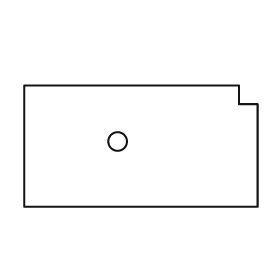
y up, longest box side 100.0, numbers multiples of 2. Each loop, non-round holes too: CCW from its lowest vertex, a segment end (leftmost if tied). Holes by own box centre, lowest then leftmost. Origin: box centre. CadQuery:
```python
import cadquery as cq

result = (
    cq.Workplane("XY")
    .moveTo(-50.0, -26.0)
    .lineTo(50.0, -26.0)
    .lineTo(50.0, 18.0)
    .lineTo(42.0, 18.0)
    .lineTo(42.0, 26.0)
    .lineTo(-50.0, 26.0)
    .close()
    .moveTo(-10.0, 2.0)
    .circle(4.0)
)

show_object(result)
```